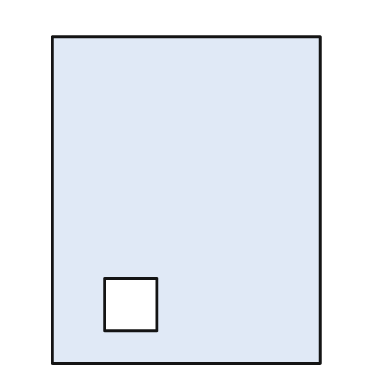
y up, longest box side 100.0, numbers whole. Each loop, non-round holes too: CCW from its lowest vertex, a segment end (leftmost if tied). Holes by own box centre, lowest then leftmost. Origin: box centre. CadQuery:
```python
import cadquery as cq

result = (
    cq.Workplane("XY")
    .moveTo(-41.0, -50.0)
    .lineTo(41.0, -50.0)
    .lineTo(41.0, 50.0)
    .lineTo(-41.0, 50.0)
    .close()
    .moveTo(-25.0, -40.0)
    .lineTo(-9.0, -40.0)
    .lineTo(-9.0, -24.0)
    .lineTo(-25.0, -24.0)
    .close()
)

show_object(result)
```